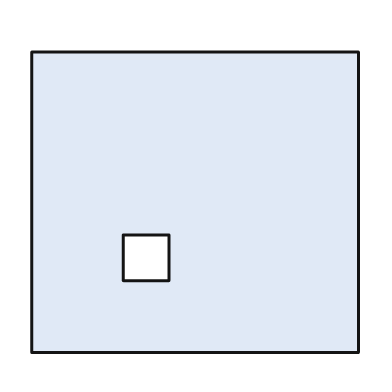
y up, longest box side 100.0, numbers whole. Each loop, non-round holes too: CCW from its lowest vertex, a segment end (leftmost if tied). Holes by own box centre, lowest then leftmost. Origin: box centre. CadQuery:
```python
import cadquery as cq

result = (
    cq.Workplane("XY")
    .moveTo(-50.0, -46.0)
    .lineTo(50.0, -46.0)
    .lineTo(50.0, 46.0)
    .lineTo(-50.0, 46.0)
    .close()
    .moveTo(-22.0, -24.0)
    .lineTo(-8.0, -24.0)
    .lineTo(-8.0, -10.0)
    .lineTo(-22.0, -10.0)
    .close()
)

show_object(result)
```